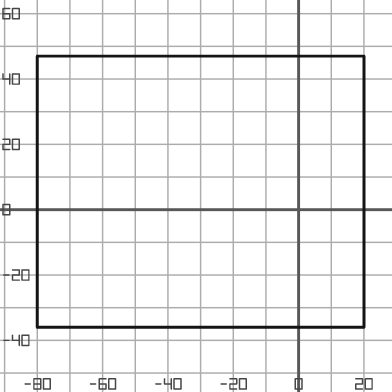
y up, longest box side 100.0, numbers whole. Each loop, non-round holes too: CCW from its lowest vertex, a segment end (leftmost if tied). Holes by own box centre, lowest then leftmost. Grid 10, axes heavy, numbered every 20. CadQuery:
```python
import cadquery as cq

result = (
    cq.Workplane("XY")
    .moveTo(-80.0, -36.0)
    .lineTo(20.0, -36.0)
    .lineTo(20.0, 47.0)
    .lineTo(-80.0, 47.0)
    .close()
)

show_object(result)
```